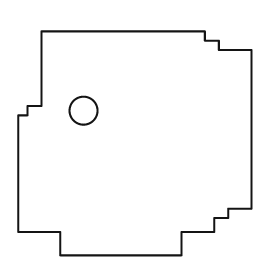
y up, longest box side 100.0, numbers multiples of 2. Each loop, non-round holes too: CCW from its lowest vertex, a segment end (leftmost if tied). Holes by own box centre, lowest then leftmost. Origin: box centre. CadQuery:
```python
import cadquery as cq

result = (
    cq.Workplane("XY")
    .moveTo(-32.0, -48.0)
    .lineTo(20.0, -48.0)
    .lineTo(20.0, -38.0)
    .lineTo(34.0, -38.0)
    .lineTo(34.0, -32.0)
    .lineTo(40.0, -32.0)
    .lineTo(40.0, -28.0)
    .lineTo(50.0, -28.0)
    .lineTo(50.0, 40.0)
    .lineTo(36.0, 40.0)
    .lineTo(36.0, 44.0)
    .lineTo(30.0, 44.0)
    .lineTo(30.0, 48.0)
    .lineTo(-40.0, 48.0)
    .lineTo(-40.0, 16.0)
    .lineTo(-46.0, 16.0)
    .lineTo(-46.0, 12.0)
    .lineTo(-50.0, 12.0)
    .lineTo(-50.0, -38.0)
    .lineTo(-32.0, -38.0)
    .close()
    .moveTo(-22.0, 14.0)
    .circle(6.0)
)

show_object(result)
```